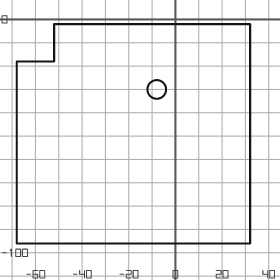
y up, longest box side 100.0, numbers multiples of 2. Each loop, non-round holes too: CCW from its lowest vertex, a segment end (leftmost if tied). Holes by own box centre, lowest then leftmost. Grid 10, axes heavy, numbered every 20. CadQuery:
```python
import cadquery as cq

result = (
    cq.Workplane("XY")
    .moveTo(-68.0, -96.0)
    .lineTo(32.0, -96.0)
    .lineTo(32.0, -2.0)
    .lineTo(-52.0, -2.0)
    .lineTo(-52.0, -18.0)
    .lineTo(-68.0, -18.0)
    .close()
    .moveTo(-8.0, -30.0)
    .circle(4.0)
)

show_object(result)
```